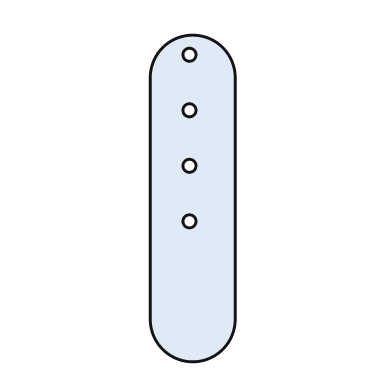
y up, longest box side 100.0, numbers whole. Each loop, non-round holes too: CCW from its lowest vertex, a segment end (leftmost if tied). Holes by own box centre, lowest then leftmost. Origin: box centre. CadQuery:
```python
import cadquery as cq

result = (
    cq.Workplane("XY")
    .moveTo(-13.0, -37.0)
    .threePointArc((0.0, -50.0), (13.0, -37.0))
    .lineTo(13.0, 37.0)
    .threePointArc((0.0, 50.0), (-13.0, 37.0))
    .close()
    .moveTo(-1.0, -7.0)
    .circle(2.0)
    .moveTo(-1.0, 10.0)
    .circle(2.0)
    .moveTo(-1.0, 27.0)
    .circle(2.0)
    .moveTo(-1.0, 44.0)
    .circle(2.0)
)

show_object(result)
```